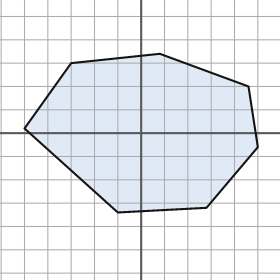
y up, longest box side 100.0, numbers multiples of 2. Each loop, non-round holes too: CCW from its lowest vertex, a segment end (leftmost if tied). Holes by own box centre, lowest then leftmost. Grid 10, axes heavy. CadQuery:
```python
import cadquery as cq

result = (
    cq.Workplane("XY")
    .moveTo(-10.0, -34.0)
    .lineTo(28.0, -32.0)
    .lineTo(50.0, -6.0)
    .lineTo(46.0, 20.0)
    .lineTo(8.0, 34.0)
    .lineTo(-30.0, 30.0)
    .lineTo(-50.0, 2.0)
    .close()
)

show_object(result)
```